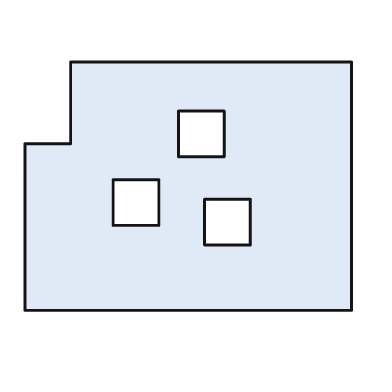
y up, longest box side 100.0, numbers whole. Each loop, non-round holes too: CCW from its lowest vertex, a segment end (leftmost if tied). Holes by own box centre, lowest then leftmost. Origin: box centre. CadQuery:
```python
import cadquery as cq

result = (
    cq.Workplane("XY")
    .moveTo(-50.0, -38.0)
    .lineTo(50.0, -38.0)
    .lineTo(50.0, 38.0)
    .lineTo(-36.0, 38.0)
    .lineTo(-36.0, 13.0)
    .lineTo(-50.0, 13.0)
    .close()
    .moveTo(5.0, -18.0)
    .lineTo(19.0, -18.0)
    .lineTo(19.0, -4.0)
    .lineTo(5.0, -4.0)
    .close()
    .moveTo(-23.0, -12.0)
    .lineTo(-9.0, -12.0)
    .lineTo(-9.0, 2.0)
    .lineTo(-23.0, 2.0)
    .close()
    .moveTo(-3.0, 9.0)
    .lineTo(11.0, 9.0)
    .lineTo(11.0, 23.0)
    .lineTo(-3.0, 23.0)
    .close()
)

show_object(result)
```